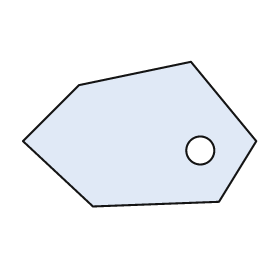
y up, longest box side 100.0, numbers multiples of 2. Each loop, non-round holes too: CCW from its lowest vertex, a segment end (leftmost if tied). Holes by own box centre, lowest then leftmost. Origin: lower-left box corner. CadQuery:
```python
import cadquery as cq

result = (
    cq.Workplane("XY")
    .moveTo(30.0, 0.0)
    .lineTo(84.0, 2.0)
    .lineTo(100.0, 28.0)
    .lineTo(72.0, 62.0)
    .lineTo(24.0, 52.0)
    .lineTo(0.0, 28.0)
    .close()
    .moveTo(76.0, 24.0)
    .circle(6.0)
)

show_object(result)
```